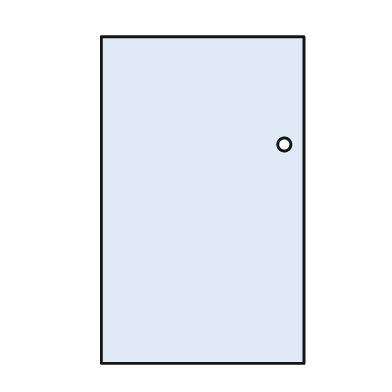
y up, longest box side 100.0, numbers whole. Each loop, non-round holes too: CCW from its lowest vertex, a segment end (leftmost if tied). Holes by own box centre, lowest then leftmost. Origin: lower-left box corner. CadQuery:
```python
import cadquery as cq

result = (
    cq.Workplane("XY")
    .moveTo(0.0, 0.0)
    .lineTo(62.0, 0.0)
    .lineTo(62.0, 100.0)
    .lineTo(0.0, 100.0)
    .close()
    .moveTo(56.0, 67.0)
    .circle(2.0)
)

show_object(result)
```